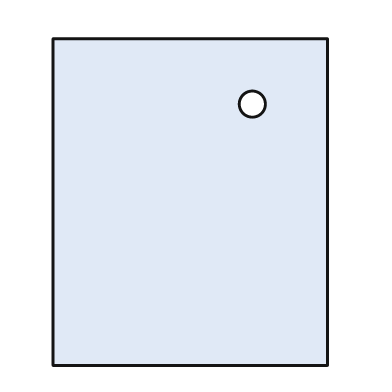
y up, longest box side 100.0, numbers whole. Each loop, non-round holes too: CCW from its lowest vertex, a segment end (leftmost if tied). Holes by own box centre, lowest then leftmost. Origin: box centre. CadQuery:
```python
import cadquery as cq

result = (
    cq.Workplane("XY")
    .moveTo(-42.0, -50.0)
    .lineTo(42.0, -50.0)
    .lineTo(42.0, 50.0)
    .lineTo(-42.0, 50.0)
    .close()
    .moveTo(19.0, 30.0)
    .circle(4.0)
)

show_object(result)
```